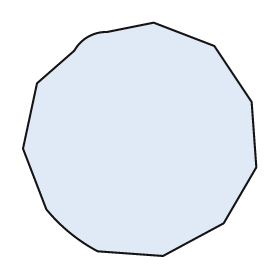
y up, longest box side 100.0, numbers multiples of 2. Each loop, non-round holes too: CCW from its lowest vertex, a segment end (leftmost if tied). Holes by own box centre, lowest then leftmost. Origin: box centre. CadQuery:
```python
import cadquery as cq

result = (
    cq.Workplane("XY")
    .moveTo(10.0, -50.0)
    .lineTo(36.0, -36.0)
    .lineTo(50.0, -12.0)
    .lineTo(48.0, 16.0)
    .lineTo(32.0, 40.0)
    .lineTo(6.0, 50.0)
    .lineTo(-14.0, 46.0)
    .threePointArc((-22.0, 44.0), (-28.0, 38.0))
    .lineTo(-44.0, 24.0)
    .lineTo(-50.0, -4.0)
    .lineTo(-40.0, -30.0)
    .threePointArc((-30.0, -40.0), (-18.0, -48.0))
    .close()
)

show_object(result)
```